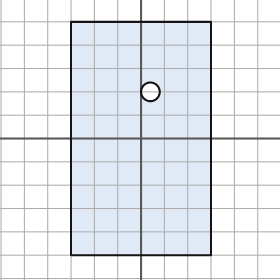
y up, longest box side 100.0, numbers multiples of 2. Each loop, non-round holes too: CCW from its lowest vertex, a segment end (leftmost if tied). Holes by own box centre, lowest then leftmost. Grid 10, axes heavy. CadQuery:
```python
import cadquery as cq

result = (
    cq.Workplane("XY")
    .moveTo(-30.0, -50.0)
    .lineTo(30.0, -50.0)
    .lineTo(30.0, 50.0)
    .lineTo(-30.0, 50.0)
    .close()
    .moveTo(4.0, 20.0)
    .circle(4.0)
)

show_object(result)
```